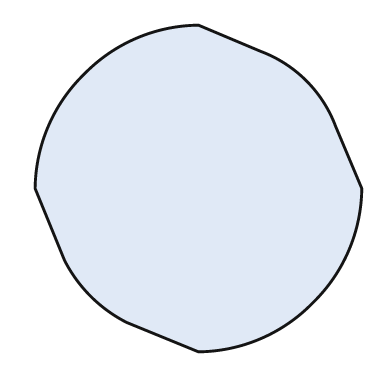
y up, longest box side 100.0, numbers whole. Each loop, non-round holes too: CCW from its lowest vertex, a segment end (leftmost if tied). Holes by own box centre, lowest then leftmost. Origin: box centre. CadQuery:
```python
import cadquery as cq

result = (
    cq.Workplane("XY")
    .moveTo(0.0, -50.0)
    .threePointArc((19.0, -46.0), (35.0, -35.0))
    .threePointArc((46.0, -19.0), (50.0, 0.0))
    .lineTo(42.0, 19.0)
    .threePointArc((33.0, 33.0), (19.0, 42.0))
    .lineTo(0.0, 50.0)
    .threePointArc((-19.0, 46.0), (-35.0, 35.0))
    .threePointArc((-46.0, 19.0), (-50.0, 0.0))
    .lineTo(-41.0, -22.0)
    .threePointArc((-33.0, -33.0), (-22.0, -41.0))
    .close()
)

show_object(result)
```